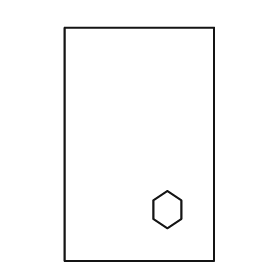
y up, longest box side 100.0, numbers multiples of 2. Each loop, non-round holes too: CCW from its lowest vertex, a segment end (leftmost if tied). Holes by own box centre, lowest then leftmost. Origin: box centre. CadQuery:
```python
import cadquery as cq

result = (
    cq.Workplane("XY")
    .moveTo(-32.0, -50.0)
    .lineTo(32.0, -50.0)
    .lineTo(32.0, 50.0)
    .lineTo(-32.0, 50.0)
    .close()
    .moveTo(12.0, -36.0)
    .lineTo(18.0, -32.0)
    .lineTo(18.0, -24.0)
    .lineTo(12.0, -20.0)
    .lineTo(6.0, -24.0)
    .lineTo(6.0, -32.0)
    .close()
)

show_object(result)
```